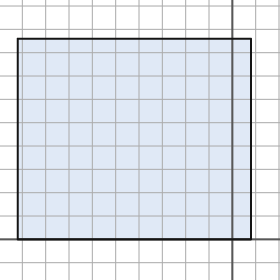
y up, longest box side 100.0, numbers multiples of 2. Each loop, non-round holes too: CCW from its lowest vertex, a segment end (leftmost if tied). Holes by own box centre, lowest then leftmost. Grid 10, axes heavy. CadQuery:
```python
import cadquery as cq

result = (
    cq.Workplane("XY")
    .moveTo(-92.0, 0.0)
    .lineTo(8.0, 0.0)
    .lineTo(8.0, 86.0)
    .lineTo(-92.0, 86.0)
    .close()
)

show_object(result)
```